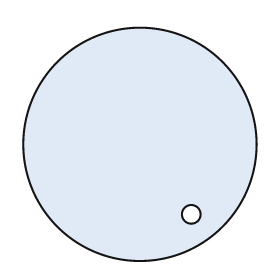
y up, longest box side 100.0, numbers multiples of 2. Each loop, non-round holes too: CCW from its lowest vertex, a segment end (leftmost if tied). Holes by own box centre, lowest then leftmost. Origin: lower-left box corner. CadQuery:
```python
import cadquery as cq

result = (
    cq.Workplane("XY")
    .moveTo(50.0, 50.0)
    .circle(50.0)
    .moveTo(72.0, 20.0)
    .circle(4.0)
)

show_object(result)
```